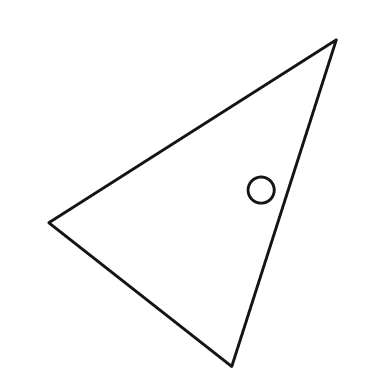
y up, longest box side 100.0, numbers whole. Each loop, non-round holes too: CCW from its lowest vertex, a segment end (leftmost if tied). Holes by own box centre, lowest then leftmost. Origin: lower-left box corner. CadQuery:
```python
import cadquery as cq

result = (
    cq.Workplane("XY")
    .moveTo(56.0, 0.0)
    .lineTo(88.0, 100.0)
    .lineTo(0.0, 44.0)
    .close()
    .moveTo(65.0, 54.0)
    .circle(4.0)
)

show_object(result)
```